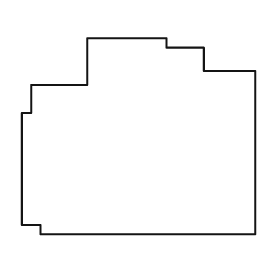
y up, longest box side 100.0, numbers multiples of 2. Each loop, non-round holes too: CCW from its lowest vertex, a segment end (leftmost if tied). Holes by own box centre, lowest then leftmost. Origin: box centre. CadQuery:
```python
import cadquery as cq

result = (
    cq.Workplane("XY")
    .moveTo(-42.0, -42.0)
    .lineTo(50.0, -42.0)
    .lineTo(50.0, 28.0)
    .lineTo(28.0, 28.0)
    .lineTo(28.0, 38.0)
    .lineTo(12.0, 38.0)
    .lineTo(12.0, 42.0)
    .lineTo(-22.0, 42.0)
    .lineTo(-22.0, 22.0)
    .lineTo(-46.0, 22.0)
    .lineTo(-46.0, 10.0)
    .lineTo(-50.0, 10.0)
    .lineTo(-50.0, -38.0)
    .lineTo(-42.0, -38.0)
    .close()
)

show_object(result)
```